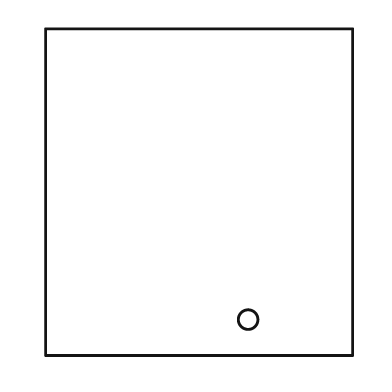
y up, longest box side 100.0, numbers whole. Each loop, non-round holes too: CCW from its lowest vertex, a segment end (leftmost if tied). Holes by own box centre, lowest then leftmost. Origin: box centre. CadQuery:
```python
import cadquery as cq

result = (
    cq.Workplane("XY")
    .moveTo(-47.0, -50.0)
    .lineTo(47.0, -50.0)
    .lineTo(47.0, 50.0)
    .lineTo(-47.0, 50.0)
    .close()
    .moveTo(15.0, -39.0)
    .circle(3.0)
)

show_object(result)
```